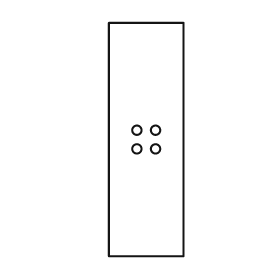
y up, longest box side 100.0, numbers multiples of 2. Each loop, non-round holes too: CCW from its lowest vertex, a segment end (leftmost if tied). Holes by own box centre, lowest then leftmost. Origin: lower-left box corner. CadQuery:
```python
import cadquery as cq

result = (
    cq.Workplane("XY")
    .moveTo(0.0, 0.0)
    .lineTo(32.0, 0.0)
    .lineTo(32.0, 100.0)
    .lineTo(0.0, 100.0)
    .close()
    .moveTo(12.0, 46.0)
    .circle(2.0)
    .moveTo(20.0, 46.0)
    .circle(2.0)
    .moveTo(12.0, 54.0)
    .circle(2.0)
    .moveTo(20.0, 54.0)
    .circle(2.0)
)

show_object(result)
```